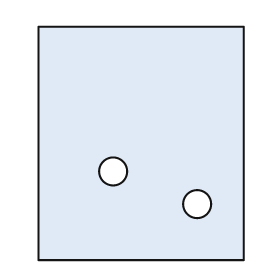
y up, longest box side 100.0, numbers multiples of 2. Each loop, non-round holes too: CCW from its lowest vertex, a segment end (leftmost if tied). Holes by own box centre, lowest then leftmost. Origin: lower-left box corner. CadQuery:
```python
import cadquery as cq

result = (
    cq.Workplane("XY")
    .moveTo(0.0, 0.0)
    .lineTo(88.0, 0.0)
    .lineTo(88.0, 100.0)
    .lineTo(0.0, 100.0)
    .close()
    .moveTo(68.0, 24.0)
    .circle(6.0)
    .moveTo(32.0, 38.0)
    .circle(6.0)
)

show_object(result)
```